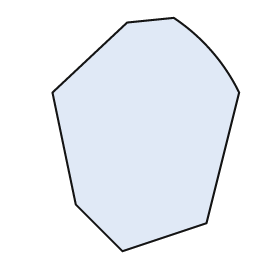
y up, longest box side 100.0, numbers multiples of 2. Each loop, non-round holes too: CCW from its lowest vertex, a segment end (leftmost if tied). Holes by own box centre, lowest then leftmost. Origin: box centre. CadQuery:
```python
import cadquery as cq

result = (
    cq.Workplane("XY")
    .moveTo(-10.0, -50.0)
    .lineTo(26.0, -38.0)
    .lineTo(40.0, 18.0)
    .threePointArc((28.0, 36.0), (12.0, 50.0))
    .lineTo(-8.0, 48.0)
    .lineTo(-40.0, 18.0)
    .lineTo(-30.0, -30.0)
    .close()
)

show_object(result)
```